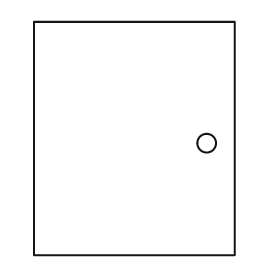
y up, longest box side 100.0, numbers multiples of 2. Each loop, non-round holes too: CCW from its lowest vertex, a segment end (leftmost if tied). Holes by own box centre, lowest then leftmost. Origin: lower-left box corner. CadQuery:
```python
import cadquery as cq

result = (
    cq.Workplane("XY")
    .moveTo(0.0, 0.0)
    .lineTo(86.0, 0.0)
    .lineTo(86.0, 100.0)
    .lineTo(0.0, 100.0)
    .close()
    .moveTo(74.0, 48.0)
    .circle(4.0)
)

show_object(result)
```